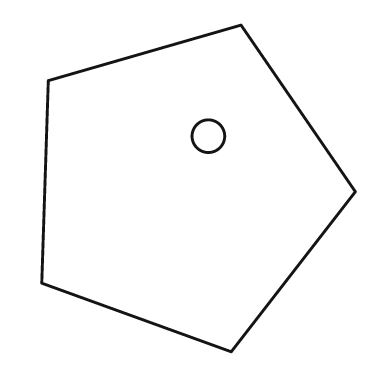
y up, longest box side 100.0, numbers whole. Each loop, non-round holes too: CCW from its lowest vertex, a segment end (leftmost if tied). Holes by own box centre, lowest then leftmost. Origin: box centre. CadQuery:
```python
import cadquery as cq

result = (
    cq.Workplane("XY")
    .moveTo(10.0, -50.0)
    .lineTo(48.0, -1.0)
    .lineTo(13.0, 50.0)
    .lineTo(-46.0, 33.0)
    .lineTo(-48.0, -29.0)
    .close()
    .moveTo(3.0, 16.0)
    .circle(5.0)
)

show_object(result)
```